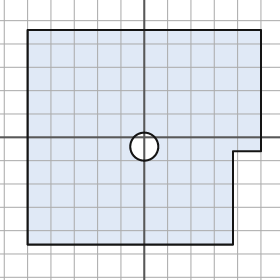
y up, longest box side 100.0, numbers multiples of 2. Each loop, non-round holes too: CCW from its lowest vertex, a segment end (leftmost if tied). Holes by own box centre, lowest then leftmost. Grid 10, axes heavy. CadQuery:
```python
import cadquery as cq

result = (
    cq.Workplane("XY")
    .moveTo(-50.0, -46.0)
    .lineTo(38.0, -46.0)
    .lineTo(38.0, -6.0)
    .lineTo(50.0, -6.0)
    .lineTo(50.0, 46.0)
    .lineTo(-50.0, 46.0)
    .close()
    .moveTo(0.0, -4.0)
    .circle(6.0)
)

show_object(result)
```